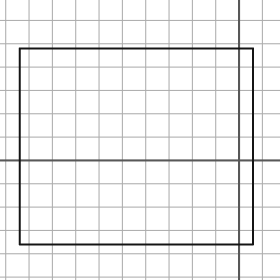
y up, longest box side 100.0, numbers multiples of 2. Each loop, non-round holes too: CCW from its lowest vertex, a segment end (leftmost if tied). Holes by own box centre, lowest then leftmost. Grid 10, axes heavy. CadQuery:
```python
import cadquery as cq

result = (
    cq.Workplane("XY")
    .moveTo(-94.0, -36.0)
    .lineTo(6.0, -36.0)
    .lineTo(6.0, 48.0)
    .lineTo(-94.0, 48.0)
    .close()
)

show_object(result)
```